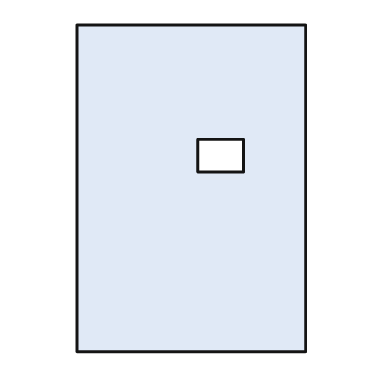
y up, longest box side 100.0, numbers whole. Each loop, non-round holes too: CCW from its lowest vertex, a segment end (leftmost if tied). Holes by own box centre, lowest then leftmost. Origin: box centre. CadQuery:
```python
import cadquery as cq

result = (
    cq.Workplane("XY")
    .moveTo(-35.0, -50.0)
    .lineTo(35.0, -50.0)
    .lineTo(35.0, 50.0)
    .lineTo(-35.0, 50.0)
    .close()
    .moveTo(2.0, 5.0)
    .lineTo(16.0, 5.0)
    .lineTo(16.0, 15.0)
    .lineTo(2.0, 15.0)
    .close()
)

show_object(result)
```